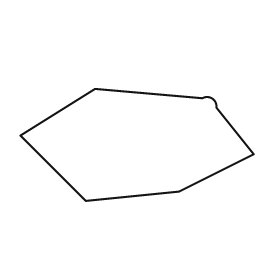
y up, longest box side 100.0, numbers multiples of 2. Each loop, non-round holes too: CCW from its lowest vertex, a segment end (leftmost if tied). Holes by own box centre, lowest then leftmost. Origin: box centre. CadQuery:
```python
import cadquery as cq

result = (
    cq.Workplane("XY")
    .moveTo(-22.0, -24.0)
    .lineTo(18.0, -20.0)
    .lineTo(50.0, -4.0)
    .lineTo(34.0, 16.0)
    .threePointArc((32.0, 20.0), (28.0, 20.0))
    .lineTo(-18.0, 24.0)
    .lineTo(-50.0, 4.0)
    .close()
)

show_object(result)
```